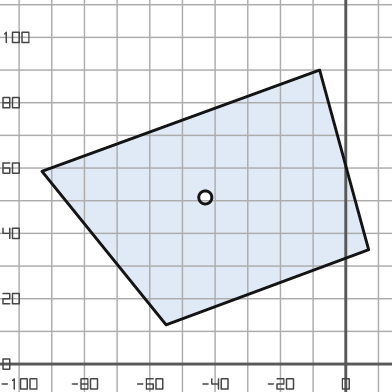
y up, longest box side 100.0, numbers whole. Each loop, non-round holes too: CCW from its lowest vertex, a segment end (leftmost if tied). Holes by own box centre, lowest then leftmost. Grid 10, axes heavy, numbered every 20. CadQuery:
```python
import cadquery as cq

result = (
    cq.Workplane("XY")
    .moveTo(-55.0, 12.0)
    .lineTo(7.0, 35.0)
    .lineTo(-8.0, 90.0)
    .lineTo(-93.0, 59.0)
    .close()
    .moveTo(-43.0, 51.0)
    .circle(2.0)
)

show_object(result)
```